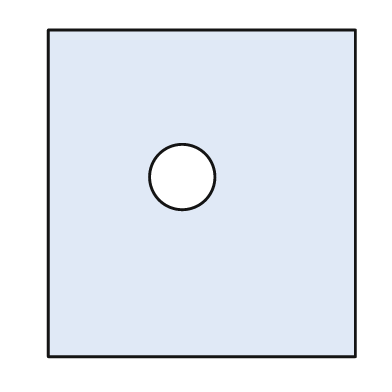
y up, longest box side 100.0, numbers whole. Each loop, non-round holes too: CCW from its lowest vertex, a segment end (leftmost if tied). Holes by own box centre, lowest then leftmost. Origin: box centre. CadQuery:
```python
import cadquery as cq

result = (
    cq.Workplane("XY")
    .moveTo(-47.0, -50.0)
    .lineTo(47.0, -50.0)
    .lineTo(47.0, 50.0)
    .lineTo(-47.0, 50.0)
    .close()
    .moveTo(-6.0, 5.0)
    .circle(10.0)
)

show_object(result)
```